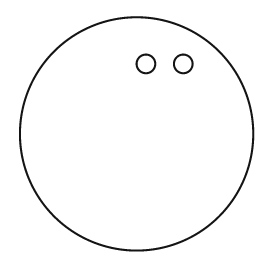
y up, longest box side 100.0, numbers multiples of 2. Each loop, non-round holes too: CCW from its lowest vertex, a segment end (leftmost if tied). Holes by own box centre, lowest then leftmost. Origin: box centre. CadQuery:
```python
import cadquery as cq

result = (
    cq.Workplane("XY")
    .moveTo(0.0, 0.0)
    .circle(50.0)
    .moveTo(4.0, 30.0)
    .circle(4.0)
    .moveTo(20.0, 30.0)
    .circle(4.0)
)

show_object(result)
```